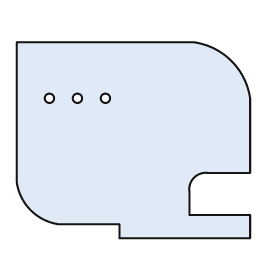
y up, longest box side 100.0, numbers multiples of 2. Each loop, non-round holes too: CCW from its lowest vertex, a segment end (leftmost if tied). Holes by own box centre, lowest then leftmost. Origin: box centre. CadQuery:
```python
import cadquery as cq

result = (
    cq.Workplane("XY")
    .moveTo(-6.0, -42.0)
    .lineTo(50.0, -42.0)
    .lineTo(50.0, -32.0)
    .lineTo(24.0, -32.0)
    .lineTo(24.0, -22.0)
    .threePointArc((26.0, -16.0), (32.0, -14.0))
    .lineTo(50.0, -14.0)
    .lineTo(50.0, 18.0)
    .threePointArc((42.0, 34.0), (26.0, 42.0))
    .lineTo(-50.0, 42.0)
    .lineTo(-50.0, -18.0)
    .threePointArc((-44.0, -30.0), (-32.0, -36.0))
    .lineTo(-6.0, -36.0)
    .close()
    .moveTo(-36.0, 18.0)
    .circle(2.0)
    .moveTo(-24.0, 18.0)
    .circle(2.0)
    .moveTo(-12.0, 18.0)
    .circle(2.0)
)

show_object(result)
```